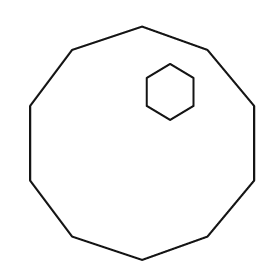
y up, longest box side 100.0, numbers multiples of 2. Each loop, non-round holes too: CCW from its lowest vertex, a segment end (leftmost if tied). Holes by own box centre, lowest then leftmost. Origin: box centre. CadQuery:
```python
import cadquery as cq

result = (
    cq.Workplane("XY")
    .moveTo(0.0, -50.0)
    .lineTo(28.0, -40.0)
    .lineTo(48.0, -16.0)
    .lineTo(48.0, 16.0)
    .lineTo(28.0, 40.0)
    .lineTo(0.0, 50.0)
    .lineTo(-30.0, 40.0)
    .lineTo(-48.0, 16.0)
    .lineTo(-48.0, -16.0)
    .lineTo(-30.0, -40.0)
    .close()
    .moveTo(12.0, 10.0)
    .lineTo(22.0, 16.0)
    .lineTo(22.0, 28.0)
    .lineTo(12.0, 34.0)
    .lineTo(2.0, 28.0)
    .lineTo(2.0, 16.0)
    .close()
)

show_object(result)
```